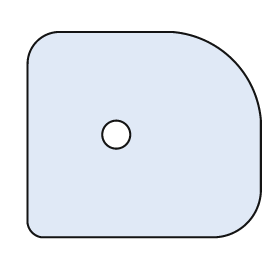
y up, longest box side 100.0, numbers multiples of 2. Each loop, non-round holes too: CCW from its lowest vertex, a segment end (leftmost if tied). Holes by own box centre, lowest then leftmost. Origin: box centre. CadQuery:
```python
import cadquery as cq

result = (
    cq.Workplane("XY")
    .moveTo(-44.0, -44.0)
    .lineTo(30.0, -44.0)
    .threePointArc((44.0, -38.0), (50.0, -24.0))
    .lineTo(50.0, 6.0)
    .threePointArc((38.0, 32.0), (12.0, 44.0))
    .lineTo(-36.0, 44.0)
    .threePointArc((-46.0, 40.0), (-50.0, 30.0))
    .lineTo(-50.0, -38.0)
    .threePointArc((-48.0, -42.0), (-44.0, -44.0))
    .close()
    .moveTo(-12.0, 0.0)
    .circle(6.0)
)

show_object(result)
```